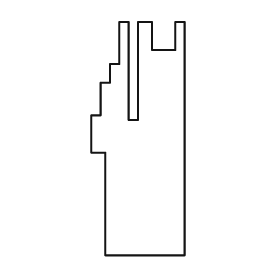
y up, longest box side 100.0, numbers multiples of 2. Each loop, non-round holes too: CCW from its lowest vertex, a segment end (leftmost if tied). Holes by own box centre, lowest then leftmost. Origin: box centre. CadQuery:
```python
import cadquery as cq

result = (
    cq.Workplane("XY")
    .moveTo(-14.0, -50.0)
    .lineTo(20.0, -50.0)
    .lineTo(20.0, 50.0)
    .lineTo(16.0, 50.0)
    .lineTo(16.0, 38.0)
    .lineTo(6.0, 38.0)
    .lineTo(6.0, 50.0)
    .lineTo(0.0, 50.0)
    .lineTo(0.0, 8.0)
    .lineTo(-4.0, 8.0)
    .lineTo(-4.0, 50.0)
    .lineTo(-8.0, 50.0)
    .lineTo(-8.0, 32.0)
    .lineTo(-12.0, 32.0)
    .lineTo(-12.0, 24.0)
    .lineTo(-16.0, 24.0)
    .lineTo(-16.0, 10.0)
    .lineTo(-20.0, 10.0)
    .lineTo(-20.0, -6.0)
    .lineTo(-14.0, -6.0)
    .close()
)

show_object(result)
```